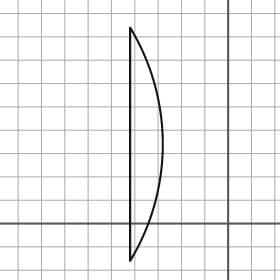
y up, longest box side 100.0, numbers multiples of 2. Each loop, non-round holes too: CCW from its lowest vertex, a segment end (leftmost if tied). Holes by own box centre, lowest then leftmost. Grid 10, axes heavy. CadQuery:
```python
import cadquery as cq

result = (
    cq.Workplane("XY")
    .moveTo(-42.0, -16.0)
    .threePointArc((-28.0, 34.0), (-42.0, 84.0))
    .close()
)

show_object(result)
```